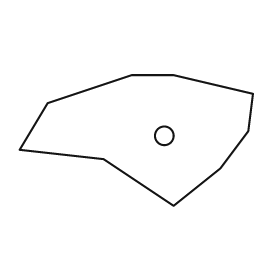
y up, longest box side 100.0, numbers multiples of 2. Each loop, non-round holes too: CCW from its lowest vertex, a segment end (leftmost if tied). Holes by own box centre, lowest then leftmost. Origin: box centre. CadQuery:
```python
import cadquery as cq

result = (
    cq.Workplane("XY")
    .moveTo(16.0, -28.0)
    .lineTo(36.0, -12.0)
    .lineTo(48.0, 4.0)
    .lineTo(50.0, 20.0)
    .lineTo(16.0, 28.0)
    .lineTo(-2.0, 28.0)
    .lineTo(-38.0, 16.0)
    .lineTo(-50.0, -4.0)
    .lineTo(-14.0, -8.0)
    .close()
    .moveTo(12.0, 2.0)
    .circle(4.0)
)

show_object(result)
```